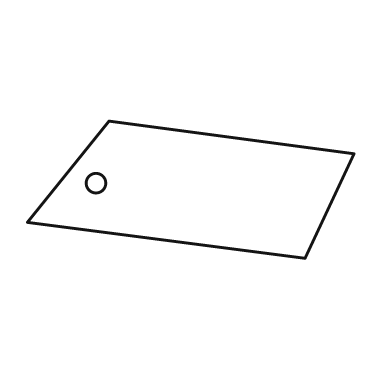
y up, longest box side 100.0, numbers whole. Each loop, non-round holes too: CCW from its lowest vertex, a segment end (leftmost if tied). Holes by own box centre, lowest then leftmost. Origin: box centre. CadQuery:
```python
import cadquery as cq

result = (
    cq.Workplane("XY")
    .moveTo(35.0, -21.0)
    .lineTo(50.0, 11.0)
    .lineTo(-25.0, 21.0)
    .lineTo(-50.0, -10.0)
    .close()
    .moveTo(-29.0, 2.0)
    .circle(3.0)
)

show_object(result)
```